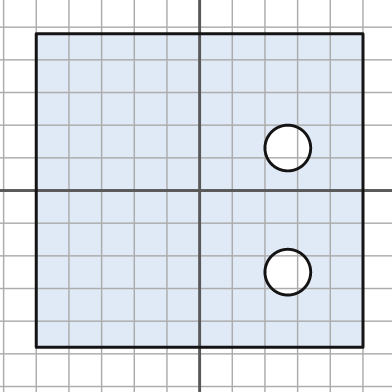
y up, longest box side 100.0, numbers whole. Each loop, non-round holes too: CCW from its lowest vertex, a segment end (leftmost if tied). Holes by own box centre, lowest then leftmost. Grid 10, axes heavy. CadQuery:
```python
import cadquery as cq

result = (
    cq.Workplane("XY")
    .moveTo(-50.0, -48.0)
    .lineTo(50.0, -48.0)
    .lineTo(50.0, 48.0)
    .lineTo(-50.0, 48.0)
    .close()
    .moveTo(27.0, -25.0)
    .circle(7.0)
    .moveTo(27.0, 13.0)
    .circle(7.0)
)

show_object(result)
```